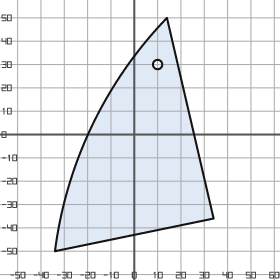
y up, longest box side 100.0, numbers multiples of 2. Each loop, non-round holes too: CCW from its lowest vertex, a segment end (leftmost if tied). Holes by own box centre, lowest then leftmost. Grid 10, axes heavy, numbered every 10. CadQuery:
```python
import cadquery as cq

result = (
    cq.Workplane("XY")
    .moveTo(-34.0, -50.0)
    .lineTo(34.0, -36.0)
    .lineTo(14.0, 50.0)
    .threePointArc((-18.0, 4.0), (-34.0, -50.0))
    .close()
    .moveTo(10.0, 30.0)
    .circle(2.0)
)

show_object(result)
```